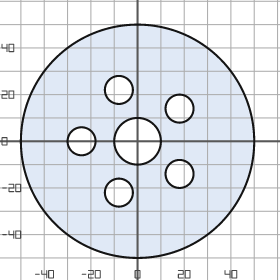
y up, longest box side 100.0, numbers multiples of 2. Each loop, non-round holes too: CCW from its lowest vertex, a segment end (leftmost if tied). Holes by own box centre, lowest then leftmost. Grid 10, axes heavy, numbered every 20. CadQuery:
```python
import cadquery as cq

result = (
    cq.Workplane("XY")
    .moveTo(0.0, 0.0)
    .circle(50.0)
    .moveTo(-8.0, -22.0)
    .circle(6.0)
    .moveTo(18.0, -14.0)
    .circle(6.0)
    .moveTo(-24.0, 0.0)
    .circle(6.0)
    .moveTo(0.0, 0.0)
    .circle(10.0)
    .moveTo(18.0, 14.0)
    .circle(6.0)
    .moveTo(-8.0, 22.0)
    .circle(6.0)
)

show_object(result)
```